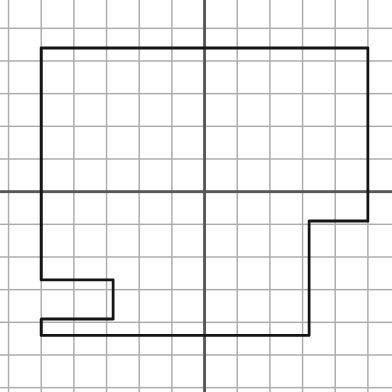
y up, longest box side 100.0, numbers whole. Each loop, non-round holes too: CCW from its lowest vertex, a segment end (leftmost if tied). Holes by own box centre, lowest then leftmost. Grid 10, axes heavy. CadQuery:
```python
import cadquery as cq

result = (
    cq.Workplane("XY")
    .moveTo(-50.0, -44.0)
    .lineTo(32.0, -44.0)
    .lineTo(32.0, -9.0)
    .lineTo(50.0, -9.0)
    .lineTo(50.0, 44.0)
    .lineTo(-50.0, 44.0)
    .lineTo(-50.0, -27.0)
    .lineTo(-28.0, -27.0)
    .lineTo(-28.0, -39.0)
    .lineTo(-50.0, -39.0)
    .close()
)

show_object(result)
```